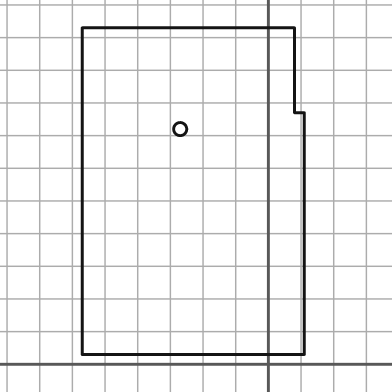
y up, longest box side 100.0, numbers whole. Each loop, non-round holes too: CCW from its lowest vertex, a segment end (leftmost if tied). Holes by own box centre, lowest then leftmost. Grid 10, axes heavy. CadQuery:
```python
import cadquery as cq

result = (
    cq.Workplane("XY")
    .moveTo(-57.0, 3.0)
    .lineTo(11.0, 3.0)
    .lineTo(11.0, 77.0)
    .lineTo(8.0, 77.0)
    .lineTo(8.0, 103.0)
    .lineTo(-57.0, 103.0)
    .close()
    .moveTo(-27.0, 72.0)
    .circle(2.0)
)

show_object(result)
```